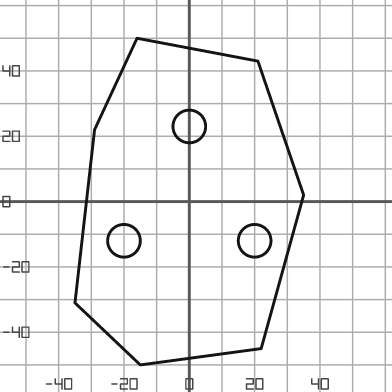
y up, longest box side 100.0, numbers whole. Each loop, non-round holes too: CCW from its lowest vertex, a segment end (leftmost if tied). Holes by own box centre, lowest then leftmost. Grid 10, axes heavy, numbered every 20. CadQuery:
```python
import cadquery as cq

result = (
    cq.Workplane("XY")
    .moveTo(-15.0, -50.0)
    .lineTo(22.0, -45.0)
    .lineTo(35.0, 2.0)
    .lineTo(21.0, 43.0)
    .lineTo(-16.0, 50.0)
    .lineTo(-29.0, 22.0)
    .lineTo(-35.0, -31.0)
    .close()
    .moveTo(-20.0, -12.0)
    .circle(5.0)
    .moveTo(20.0, -12.0)
    .circle(5.0)
    .moveTo(0.0, 23.0)
    .circle(5.0)
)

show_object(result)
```